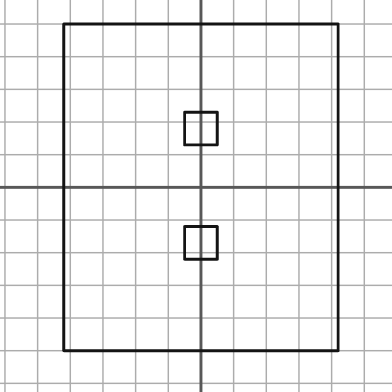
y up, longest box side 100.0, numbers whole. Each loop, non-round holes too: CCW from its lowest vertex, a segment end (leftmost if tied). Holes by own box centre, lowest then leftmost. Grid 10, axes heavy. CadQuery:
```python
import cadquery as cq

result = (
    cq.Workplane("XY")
    .moveTo(-42.0, -50.0)
    .lineTo(42.0, -50.0)
    .lineTo(42.0, 50.0)
    .lineTo(-42.0, 50.0)
    .close()
    .moveTo(-5.0, -22.0)
    .lineTo(5.0, -22.0)
    .lineTo(5.0, -12.0)
    .lineTo(-5.0, -12.0)
    .close()
    .moveTo(-5.0, 13.0)
    .lineTo(5.0, 13.0)
    .lineTo(5.0, 23.0)
    .lineTo(-5.0, 23.0)
    .close()
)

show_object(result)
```